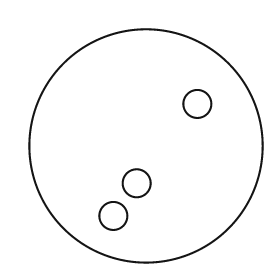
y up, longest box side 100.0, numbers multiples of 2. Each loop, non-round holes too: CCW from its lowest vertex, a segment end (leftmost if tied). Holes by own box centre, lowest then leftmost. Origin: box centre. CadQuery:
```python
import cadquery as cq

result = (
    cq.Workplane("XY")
    .moveTo(0.0, 0.0)
    .circle(50.0)
    .moveTo(-14.0, -30.0)
    .circle(6.0)
    .moveTo(-4.0, -16.0)
    .circle(6.0)
    .moveTo(22.0, 18.0)
    .circle(6.0)
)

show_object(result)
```